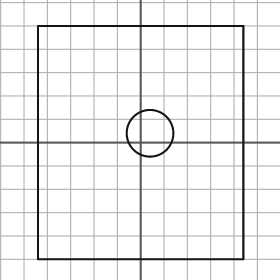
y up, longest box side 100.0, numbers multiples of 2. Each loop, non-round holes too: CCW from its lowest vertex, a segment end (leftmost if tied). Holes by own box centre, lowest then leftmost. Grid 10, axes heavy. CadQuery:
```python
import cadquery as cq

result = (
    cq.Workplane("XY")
    .moveTo(-44.0, -50.0)
    .lineTo(44.0, -50.0)
    .lineTo(44.0, 50.0)
    .lineTo(-44.0, 50.0)
    .close()
    .moveTo(4.0, 4.0)
    .circle(10.0)
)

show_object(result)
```